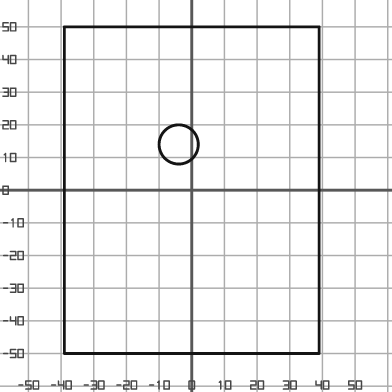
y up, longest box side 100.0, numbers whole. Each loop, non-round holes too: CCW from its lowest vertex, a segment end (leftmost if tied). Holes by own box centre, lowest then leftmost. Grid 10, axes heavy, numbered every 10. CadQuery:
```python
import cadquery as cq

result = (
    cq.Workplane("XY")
    .moveTo(-39.0, -50.0)
    .lineTo(39.0, -50.0)
    .lineTo(39.0, 50.0)
    .lineTo(-39.0, 50.0)
    .close()
    .moveTo(-4.0, 14.0)
    .circle(6.0)
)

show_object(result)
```